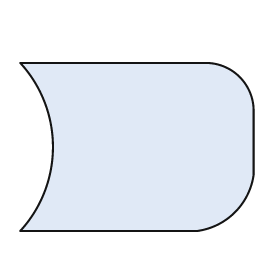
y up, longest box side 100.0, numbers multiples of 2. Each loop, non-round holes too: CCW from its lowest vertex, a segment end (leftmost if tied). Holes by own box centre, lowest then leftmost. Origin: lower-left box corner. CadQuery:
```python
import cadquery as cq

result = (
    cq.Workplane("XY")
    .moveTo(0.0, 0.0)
    .lineTo(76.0, 0.0)
    .threePointArc((92.0, 8.0), (100.0, 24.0))
    .lineTo(100.0, 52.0)
    .threePointArc((94.0, 66.0), (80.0, 72.0))
    .lineTo(0.0, 72.0)
    .threePointArc((14.0, 36.0), (0.0, 0.0))
    .close()
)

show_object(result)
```